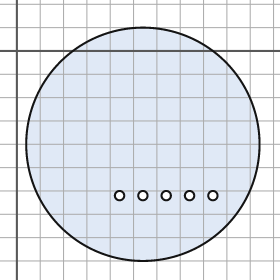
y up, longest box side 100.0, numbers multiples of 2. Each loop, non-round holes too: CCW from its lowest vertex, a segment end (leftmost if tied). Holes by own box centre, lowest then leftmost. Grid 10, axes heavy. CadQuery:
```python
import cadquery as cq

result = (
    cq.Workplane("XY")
    .moveTo(54.0, -40.0)
    .circle(50.0)
    .moveTo(44.0, -62.0)
    .circle(2.0)
    .moveTo(54.0, -62.0)
    .circle(2.0)
    .moveTo(64.0, -62.0)
    .circle(2.0)
    .moveTo(74.0, -62.0)
    .circle(2.0)
    .moveTo(84.0, -62.0)
    .circle(2.0)
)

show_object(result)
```